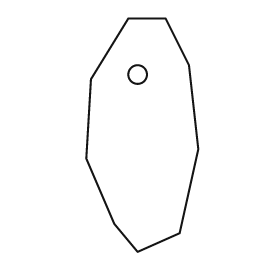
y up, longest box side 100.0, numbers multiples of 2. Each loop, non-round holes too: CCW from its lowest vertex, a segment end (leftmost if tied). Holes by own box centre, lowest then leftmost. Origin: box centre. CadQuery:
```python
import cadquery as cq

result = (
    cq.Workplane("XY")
    .moveTo(-2.0, -50.0)
    .lineTo(16.0, -42.0)
    .lineTo(24.0, -6.0)
    .lineTo(20.0, 30.0)
    .lineTo(10.0, 50.0)
    .lineTo(-6.0, 50.0)
    .lineTo(-22.0, 24.0)
    .lineTo(-24.0, -10.0)
    .lineTo(-12.0, -38.0)
    .close()
    .moveTo(-2.0, 26.0)
    .circle(4.0)
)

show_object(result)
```